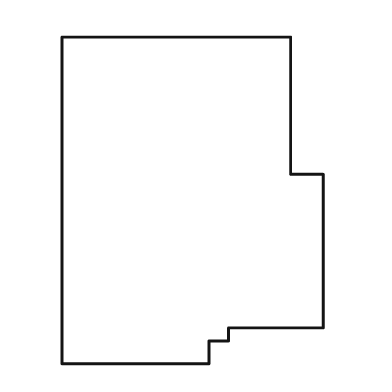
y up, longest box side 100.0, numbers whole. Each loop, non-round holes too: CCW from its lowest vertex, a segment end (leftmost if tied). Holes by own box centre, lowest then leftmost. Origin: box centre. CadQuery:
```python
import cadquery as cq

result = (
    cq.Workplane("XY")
    .moveTo(-40.0, -50.0)
    .lineTo(5.0, -50.0)
    .lineTo(5.0, -43.0)
    .lineTo(11.0, -43.0)
    .lineTo(11.0, -39.0)
    .lineTo(40.0, -39.0)
    .lineTo(40.0, 8.0)
    .lineTo(30.0, 8.0)
    .lineTo(30.0, 50.0)
    .lineTo(-40.0, 50.0)
    .close()
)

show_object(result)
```